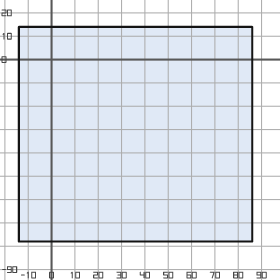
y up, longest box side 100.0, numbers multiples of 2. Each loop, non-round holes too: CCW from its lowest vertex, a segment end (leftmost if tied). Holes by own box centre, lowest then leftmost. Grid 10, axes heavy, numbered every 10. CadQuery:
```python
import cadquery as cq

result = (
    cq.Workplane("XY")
    .moveTo(-14.0, -78.0)
    .lineTo(86.0, -78.0)
    .lineTo(86.0, 14.0)
    .lineTo(-14.0, 14.0)
    .close()
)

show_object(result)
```